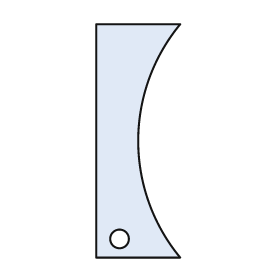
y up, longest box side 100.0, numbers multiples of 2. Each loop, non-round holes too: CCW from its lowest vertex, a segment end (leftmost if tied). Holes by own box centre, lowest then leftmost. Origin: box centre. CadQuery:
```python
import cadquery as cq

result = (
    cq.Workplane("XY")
    .moveTo(-18.0, -50.0)
    .lineTo(18.0, -50.0)
    .threePointArc((0.0, 0.0), (18.0, 50.0))
    .lineTo(-18.0, 50.0)
    .close()
    .moveTo(-8.0, -42.0)
    .circle(4.0)
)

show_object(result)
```